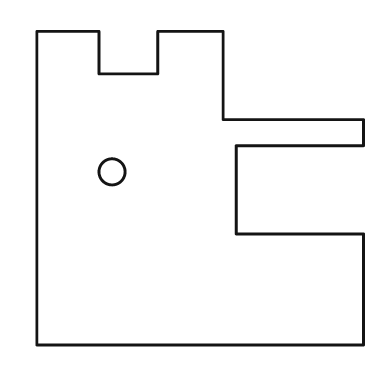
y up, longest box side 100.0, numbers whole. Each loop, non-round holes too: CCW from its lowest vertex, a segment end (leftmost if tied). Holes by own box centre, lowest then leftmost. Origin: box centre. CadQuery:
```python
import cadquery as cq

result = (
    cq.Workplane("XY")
    .moveTo(-50.0, -48.0)
    .lineTo(50.0, -48.0)
    .lineTo(50.0, -14.0)
    .lineTo(11.0, -14.0)
    .lineTo(11.0, 13.0)
    .lineTo(50.0, 13.0)
    .lineTo(50.0, 21.0)
    .lineTo(7.0, 21.0)
    .lineTo(7.0, 48.0)
    .lineTo(-13.0, 48.0)
    .lineTo(-13.0, 35.0)
    .lineTo(-31.0, 35.0)
    .lineTo(-31.0, 48.0)
    .lineTo(-50.0, 48.0)
    .close()
    .moveTo(-27.0, 5.0)
    .circle(4.0)
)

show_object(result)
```